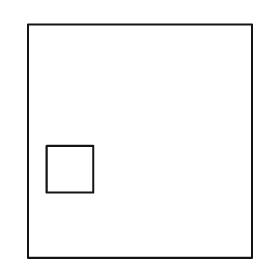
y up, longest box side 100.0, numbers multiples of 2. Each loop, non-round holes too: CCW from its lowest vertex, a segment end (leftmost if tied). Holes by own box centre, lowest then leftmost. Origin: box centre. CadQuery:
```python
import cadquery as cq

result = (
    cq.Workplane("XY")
    .moveTo(-48.0, -50.0)
    .lineTo(48.0, -50.0)
    .lineTo(48.0, 50.0)
    .lineTo(-48.0, 50.0)
    .close()
    .moveTo(-40.0, -22.0)
    .lineTo(-20.0, -22.0)
    .lineTo(-20.0, -2.0)
    .lineTo(-40.0, -2.0)
    .close()
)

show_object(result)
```